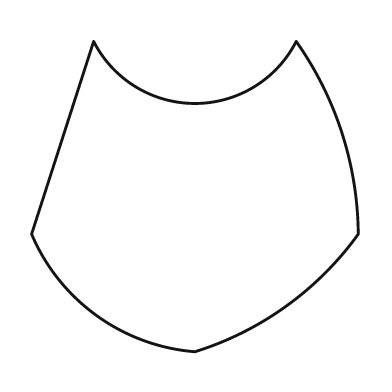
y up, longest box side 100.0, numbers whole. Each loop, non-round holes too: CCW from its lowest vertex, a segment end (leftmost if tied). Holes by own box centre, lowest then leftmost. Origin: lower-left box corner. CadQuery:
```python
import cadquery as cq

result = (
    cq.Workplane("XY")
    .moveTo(50.0, 0.0)
    .threePointArc((78.0, 14.0), (100.0, 36.0))
    .threePointArc((95.0, 67.0), (81.0, 95.0))
    .threePointArc((50.0, 76.0), (19.0, 95.0))
    .lineTo(0.0, 36.0)
    .threePointArc((20.0, 11.0), (50.0, 0.0))
    .close()
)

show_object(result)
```